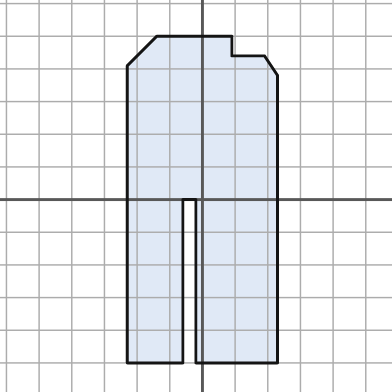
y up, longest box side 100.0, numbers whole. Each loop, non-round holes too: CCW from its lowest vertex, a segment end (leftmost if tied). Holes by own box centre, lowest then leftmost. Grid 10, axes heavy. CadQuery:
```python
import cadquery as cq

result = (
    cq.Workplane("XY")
    .moveTo(-23.0, -50.0)
    .lineTo(-6.0, -50.0)
    .lineTo(-6.0, 0.0)
    .lineTo(-2.0, 0.0)
    .lineTo(-2.0, -50.0)
    .lineTo(23.0, -50.0)
    .lineTo(23.0, 38.0)
    .lineTo(19.0, 44.0)
    .lineTo(9.0, 44.0)
    .lineTo(9.0, 50.0)
    .lineTo(-14.0, 50.0)
    .lineTo(-23.0, 41.0)
    .close()
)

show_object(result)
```